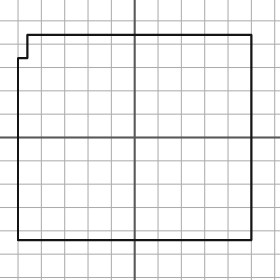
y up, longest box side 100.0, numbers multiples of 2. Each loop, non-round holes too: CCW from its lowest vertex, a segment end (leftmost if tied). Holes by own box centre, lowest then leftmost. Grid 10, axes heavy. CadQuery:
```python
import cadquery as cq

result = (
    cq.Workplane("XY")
    .moveTo(-50.0, -44.0)
    .lineTo(50.0, -44.0)
    .lineTo(50.0, 44.0)
    .lineTo(-46.0, 44.0)
    .lineTo(-46.0, 34.0)
    .lineTo(-50.0, 34.0)
    .close()
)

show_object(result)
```